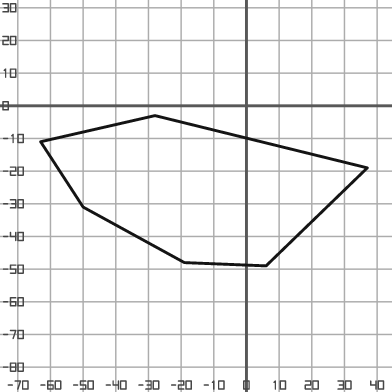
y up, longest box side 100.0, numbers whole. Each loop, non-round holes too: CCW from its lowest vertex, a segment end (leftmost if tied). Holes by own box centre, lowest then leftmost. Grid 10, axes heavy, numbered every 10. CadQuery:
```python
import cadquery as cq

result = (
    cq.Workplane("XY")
    .moveTo(6.0, -49.0)
    .lineTo(37.0, -19.0)
    .lineTo(-28.0, -3.0)
    .lineTo(-63.0, -11.0)
    .lineTo(-50.0, -31.0)
    .lineTo(-19.0, -48.0)
    .close()
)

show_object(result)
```